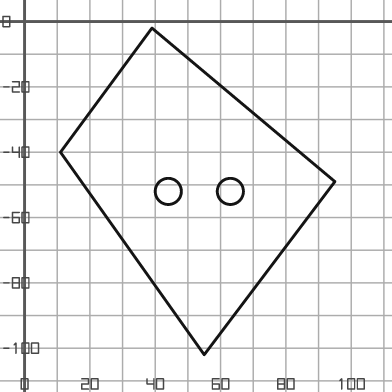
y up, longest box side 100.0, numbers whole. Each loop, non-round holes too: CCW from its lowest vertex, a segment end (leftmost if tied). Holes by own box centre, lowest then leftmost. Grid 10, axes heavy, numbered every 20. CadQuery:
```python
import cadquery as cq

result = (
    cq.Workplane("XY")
    .moveTo(55.0, -102.0)
    .lineTo(95.0, -49.0)
    .lineTo(39.0, -2.0)
    .lineTo(11.0, -40.0)
    .close()
    .moveTo(44.0, -52.0)
    .circle(4.0)
    .moveTo(63.0, -52.0)
    .circle(4.0)
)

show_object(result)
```